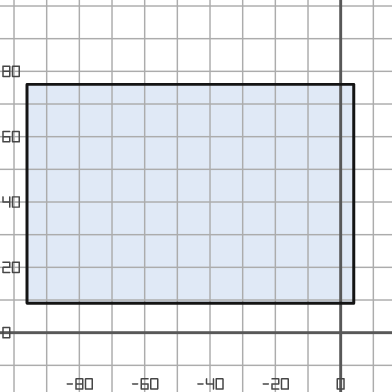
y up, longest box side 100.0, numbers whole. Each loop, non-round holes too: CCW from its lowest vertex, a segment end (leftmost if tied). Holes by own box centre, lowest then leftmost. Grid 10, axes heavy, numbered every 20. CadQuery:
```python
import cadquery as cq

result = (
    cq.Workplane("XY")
    .moveTo(-96.0, 9.0)
    .lineTo(4.0, 9.0)
    .lineTo(4.0, 76.0)
    .lineTo(-96.0, 76.0)
    .close()
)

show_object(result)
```